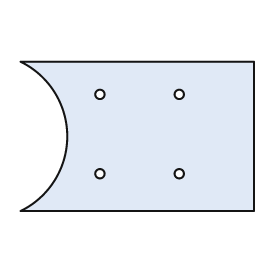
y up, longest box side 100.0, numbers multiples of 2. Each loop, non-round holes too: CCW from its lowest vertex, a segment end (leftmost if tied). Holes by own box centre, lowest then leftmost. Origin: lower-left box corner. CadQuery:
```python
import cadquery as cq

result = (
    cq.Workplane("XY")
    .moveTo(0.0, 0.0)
    .lineTo(100.0, 0.0)
    .lineTo(100.0, 64.0)
    .lineTo(0.0, 64.0)
    .threePointArc((20.0, 32.0), (0.0, 0.0))
    .close()
    .moveTo(34.0, 16.0)
    .circle(2.0)
    .moveTo(68.0, 16.0)
    .circle(2.0)
    .moveTo(34.0, 50.0)
    .circle(2.0)
    .moveTo(68.0, 50.0)
    .circle(2.0)
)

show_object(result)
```